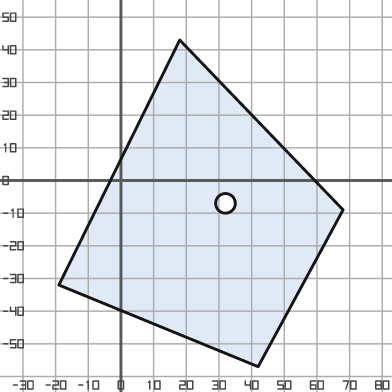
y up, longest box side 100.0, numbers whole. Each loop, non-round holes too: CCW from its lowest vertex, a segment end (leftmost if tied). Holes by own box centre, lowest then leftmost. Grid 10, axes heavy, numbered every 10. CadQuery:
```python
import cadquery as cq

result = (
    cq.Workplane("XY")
    .moveTo(42.0, -57.0)
    .lineTo(68.0, -9.0)
    .lineTo(18.0, 43.0)
    .lineTo(-19.0, -32.0)
    .close()
    .moveTo(32.0, -7.0)
    .circle(3.0)
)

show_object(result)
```